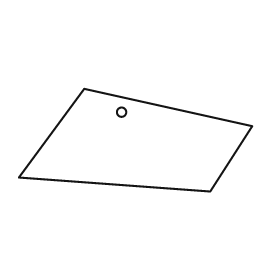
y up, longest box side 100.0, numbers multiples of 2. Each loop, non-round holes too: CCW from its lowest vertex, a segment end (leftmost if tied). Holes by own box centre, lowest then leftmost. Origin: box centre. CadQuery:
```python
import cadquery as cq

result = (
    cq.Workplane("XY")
    .moveTo(32.0, -22.0)
    .lineTo(50.0, 6.0)
    .lineTo(-22.0, 22.0)
    .lineTo(-50.0, -16.0)
    .close()
    .moveTo(-6.0, 12.0)
    .circle(2.0)
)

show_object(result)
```